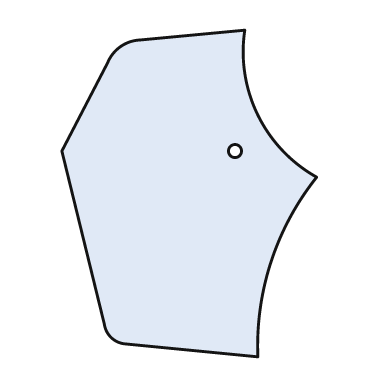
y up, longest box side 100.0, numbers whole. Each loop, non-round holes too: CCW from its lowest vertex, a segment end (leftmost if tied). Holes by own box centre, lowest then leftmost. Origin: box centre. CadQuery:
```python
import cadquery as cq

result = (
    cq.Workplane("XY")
    .moveTo(21.0, -50.0)
    .threePointArc((25.0, -21.0), (39.0, 5.0))
    .threePointArc((21.0, 24.0), (17.0, 50.0))
    .lineTo(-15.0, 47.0)
    .threePointArc((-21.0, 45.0), (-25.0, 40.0))
    .lineTo(-39.0, 13.0)
    .lineTo(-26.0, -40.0)
    .threePointArc((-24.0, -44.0), (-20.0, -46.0))
    .close()
    .moveTo(14.0, 13.0)
    .circle(2.0)
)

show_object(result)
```